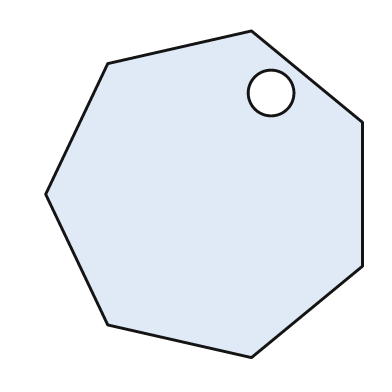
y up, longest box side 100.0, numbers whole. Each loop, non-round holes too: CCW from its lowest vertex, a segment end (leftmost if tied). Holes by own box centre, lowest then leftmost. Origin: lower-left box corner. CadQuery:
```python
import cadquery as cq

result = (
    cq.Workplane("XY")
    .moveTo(63.0, 0.0)
    .lineTo(97.0, 28.0)
    .lineTo(97.0, 72.0)
    .lineTo(63.0, 100.0)
    .lineTo(19.0, 90.0)
    .lineTo(0.0, 50.0)
    .lineTo(19.0, 10.0)
    .close()
    .moveTo(69.0, 81.0)
    .circle(7.0)
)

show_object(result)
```